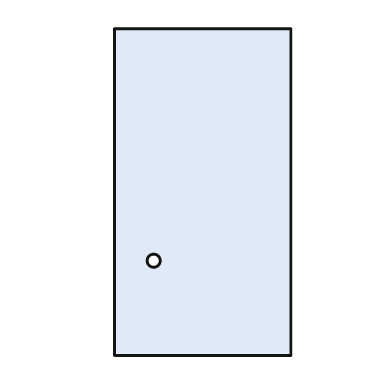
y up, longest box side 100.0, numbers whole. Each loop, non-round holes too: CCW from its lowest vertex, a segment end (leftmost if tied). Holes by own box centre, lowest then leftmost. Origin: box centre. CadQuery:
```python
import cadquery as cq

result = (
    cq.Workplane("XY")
    .moveTo(-27.0, -50.0)
    .lineTo(27.0, -50.0)
    .lineTo(27.0, 50.0)
    .lineTo(-27.0, 50.0)
    .close()
    .moveTo(-15.0, -21.0)
    .circle(2.0)
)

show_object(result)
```